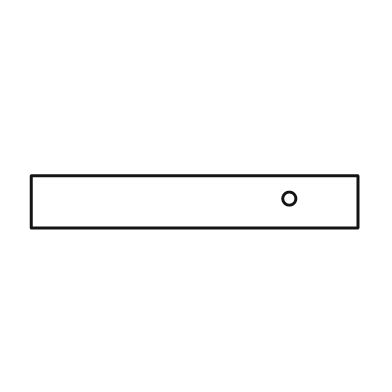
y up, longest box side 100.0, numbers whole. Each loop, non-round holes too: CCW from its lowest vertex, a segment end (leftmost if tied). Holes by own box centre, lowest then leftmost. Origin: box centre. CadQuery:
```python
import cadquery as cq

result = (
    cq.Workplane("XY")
    .moveTo(-50.0, -8.0)
    .lineTo(50.0, -8.0)
    .lineTo(50.0, 8.0)
    .lineTo(-50.0, 8.0)
    .close()
    .moveTo(29.0, 1.0)
    .circle(2.0)
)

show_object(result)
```